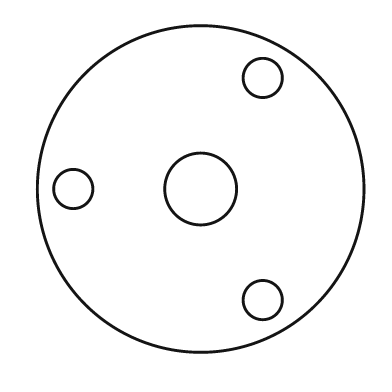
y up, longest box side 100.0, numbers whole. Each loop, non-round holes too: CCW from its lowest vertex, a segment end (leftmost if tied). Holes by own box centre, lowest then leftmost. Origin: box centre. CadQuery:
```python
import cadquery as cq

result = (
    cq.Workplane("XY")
    .moveTo(0.0, 0.0)
    .circle(50.0)
    .moveTo(19.0, -34.0)
    .circle(6.0)
    .moveTo(-39.0, 0.0)
    .circle(6.0)
    .moveTo(0.0, 0.0)
    .circle(11.0)
    .moveTo(19.0, 34.0)
    .circle(6.0)
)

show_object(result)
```